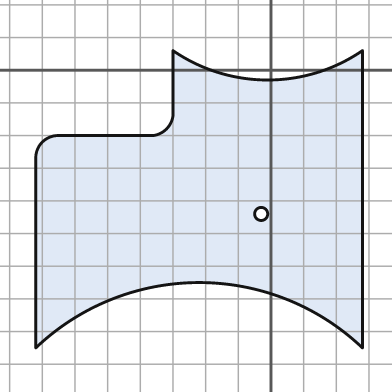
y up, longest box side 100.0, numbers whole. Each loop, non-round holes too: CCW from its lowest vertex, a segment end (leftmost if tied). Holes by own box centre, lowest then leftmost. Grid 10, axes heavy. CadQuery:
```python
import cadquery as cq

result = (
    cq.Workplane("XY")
    .moveTo(-72.0, -85.0)
    .threePointArc((-22.0, -65.0), (28.0, -85.0))
    .lineTo(28.0, 6.0)
    .threePointArc((-1.0, -3.0), (-30.0, 6.0))
    .lineTo(-30.0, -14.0)
    .threePointArc((-32.0, -18.0), (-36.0, -20.0))
    .lineTo(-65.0, -20.0)
    .threePointArc((-70.0, -22.0), (-72.0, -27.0))
    .close()
    .moveTo(-3.0, -44.0)
    .circle(2.0)
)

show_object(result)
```